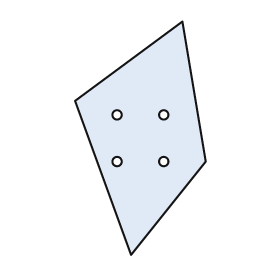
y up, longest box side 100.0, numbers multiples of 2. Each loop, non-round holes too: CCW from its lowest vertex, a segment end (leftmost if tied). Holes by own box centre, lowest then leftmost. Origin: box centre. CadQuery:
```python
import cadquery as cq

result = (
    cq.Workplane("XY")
    .moveTo(-4.0, -50.0)
    .lineTo(28.0, -10.0)
    .lineTo(18.0, 50.0)
    .lineTo(-28.0, 16.0)
    .close()
    .moveTo(-10.0, -10.0)
    .circle(2.0)
    .moveTo(10.0, -10.0)
    .circle(2.0)
    .moveTo(-10.0, 10.0)
    .circle(2.0)
    .moveTo(10.0, 10.0)
    .circle(2.0)
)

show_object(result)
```